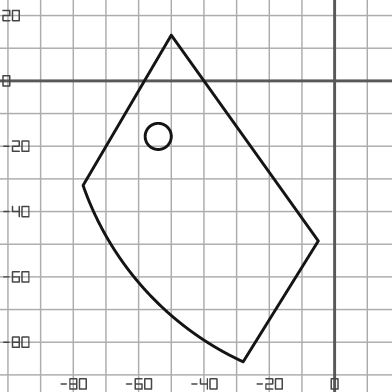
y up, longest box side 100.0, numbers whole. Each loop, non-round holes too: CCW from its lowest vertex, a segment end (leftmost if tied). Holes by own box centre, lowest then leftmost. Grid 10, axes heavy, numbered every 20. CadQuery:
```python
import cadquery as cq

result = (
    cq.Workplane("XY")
    .moveTo(-28.0, -86.0)
    .lineTo(-5.0, -49.0)
    .lineTo(-50.0, 14.0)
    .lineTo(-77.0, -32.0)
    .threePointArc((-58.0, -64.0), (-28.0, -86.0))
    .close()
    .moveTo(-54.0, -17.0)
    .circle(4.0)
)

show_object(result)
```